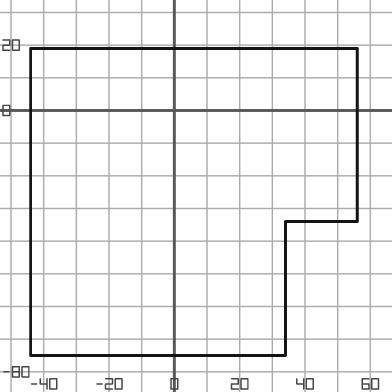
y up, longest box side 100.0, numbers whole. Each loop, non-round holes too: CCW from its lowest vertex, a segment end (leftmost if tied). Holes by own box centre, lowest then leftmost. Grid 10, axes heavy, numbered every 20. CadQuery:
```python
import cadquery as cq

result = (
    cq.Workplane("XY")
    .moveTo(-44.0, -75.0)
    .lineTo(34.0, -75.0)
    .lineTo(34.0, -34.0)
    .lineTo(56.0, -34.0)
    .lineTo(56.0, 19.0)
    .lineTo(-44.0, 19.0)
    .close()
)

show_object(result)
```